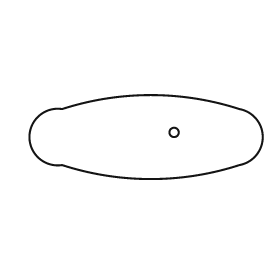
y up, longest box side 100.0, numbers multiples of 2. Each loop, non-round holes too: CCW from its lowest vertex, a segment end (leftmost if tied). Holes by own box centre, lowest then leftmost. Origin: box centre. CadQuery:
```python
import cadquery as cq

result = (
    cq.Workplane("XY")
    .moveTo(-36.0, -12.0)
    .threePointArc((2.0, -18.0), (40.0, -12.0))
    .threePointArc((50.0, 0.0), (40.0, 12.0))
    .threePointArc((2.0, 18.0), (-36.0, 12.0))
    .threePointArc((-50.0, 0.0), (-36.0, -12.0))
    .close()
    .moveTo(12.0, 2.0)
    .circle(2.0)
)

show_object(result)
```